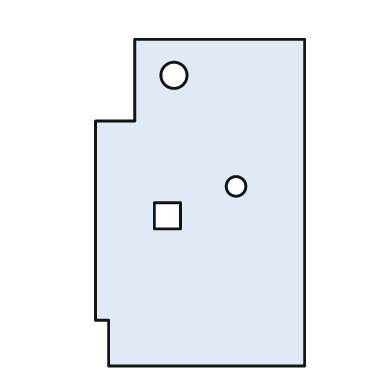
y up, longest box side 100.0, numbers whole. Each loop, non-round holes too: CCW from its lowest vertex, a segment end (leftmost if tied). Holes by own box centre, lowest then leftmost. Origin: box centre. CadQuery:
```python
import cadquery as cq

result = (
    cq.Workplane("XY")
    .moveTo(-28.0, -50.0)
    .lineTo(32.0, -50.0)
    .lineTo(32.0, 50.0)
    .lineTo(-20.0, 50.0)
    .lineTo(-20.0, 25.0)
    .lineTo(-32.0, 25.0)
    .lineTo(-32.0, -36.0)
    .lineTo(-28.0, -36.0)
    .close()
    .moveTo(-14.0, -8.0)
    .lineTo(-6.0, -8.0)
    .lineTo(-6.0, 0.0)
    .lineTo(-14.0, 0.0)
    .close()
    .moveTo(11.0, 5.0)
    .circle(3.0)
    .moveTo(-8.0, 39.0)
    .circle(4.0)
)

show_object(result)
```